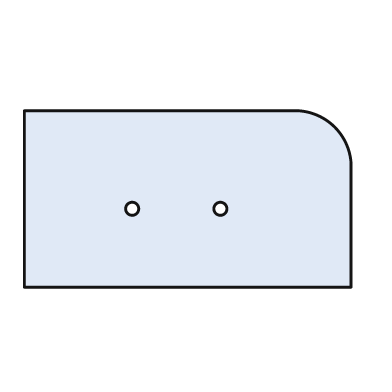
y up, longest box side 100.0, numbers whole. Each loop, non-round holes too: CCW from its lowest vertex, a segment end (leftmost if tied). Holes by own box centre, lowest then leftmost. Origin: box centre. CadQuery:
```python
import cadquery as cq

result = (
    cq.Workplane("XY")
    .moveTo(-50.0, -27.0)
    .lineTo(50.0, -27.0)
    .lineTo(50.0, 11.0)
    .threePointArc((45.0, 22.0), (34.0, 27.0))
    .lineTo(-50.0, 27.0)
    .close()
    .moveTo(-17.0, -3.0)
    .circle(2.0)
    .moveTo(10.0, -3.0)
    .circle(2.0)
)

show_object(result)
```